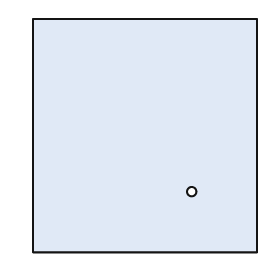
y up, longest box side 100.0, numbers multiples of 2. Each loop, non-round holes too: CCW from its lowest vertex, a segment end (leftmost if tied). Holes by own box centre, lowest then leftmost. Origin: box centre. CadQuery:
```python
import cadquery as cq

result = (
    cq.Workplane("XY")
    .moveTo(-48.0, -50.0)
    .lineTo(48.0, -50.0)
    .lineTo(48.0, 50.0)
    .lineTo(-48.0, 50.0)
    .close()
    .moveTo(20.0, -24.0)
    .circle(2.0)
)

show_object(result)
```